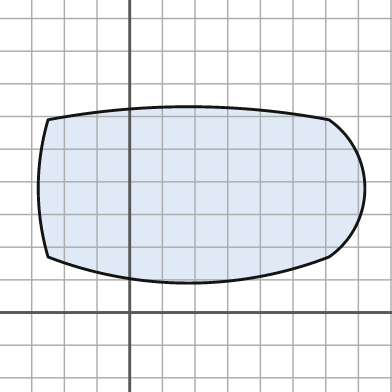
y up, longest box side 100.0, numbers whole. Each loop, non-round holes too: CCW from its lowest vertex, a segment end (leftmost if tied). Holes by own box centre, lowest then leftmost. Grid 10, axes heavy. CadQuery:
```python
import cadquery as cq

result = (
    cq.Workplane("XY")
    .moveTo(-25.0, 17.0)
    .threePointArc((18.0, 9.0), (61.0, 17.0))
    .threePointArc((72.0, 38.0), (61.0, 59.0))
    .threePointArc((18.0, 63.0), (-25.0, 59.0))
    .threePointArc((-28.0, 38.0), (-25.0, 17.0))
    .close()
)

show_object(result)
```